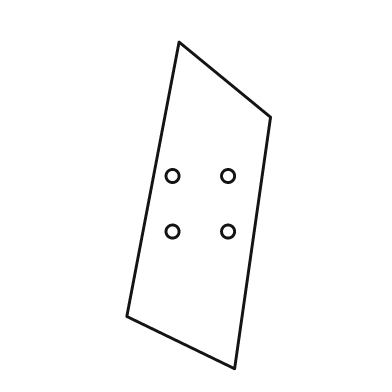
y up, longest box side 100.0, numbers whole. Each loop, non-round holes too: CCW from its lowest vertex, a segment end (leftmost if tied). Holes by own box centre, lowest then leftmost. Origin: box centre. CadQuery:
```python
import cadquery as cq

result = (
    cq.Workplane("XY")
    .moveTo(11.0, -50.0)
    .lineTo(22.0, 27.0)
    .lineTo(-6.0, 50.0)
    .lineTo(-22.0, -34.0)
    .close()
    .moveTo(-8.0, -8.0)
    .circle(2.0)
    .moveTo(9.0, -8.0)
    .circle(2.0)
    .moveTo(-8.0, 9.0)
    .circle(2.0)
    .moveTo(9.0, 9.0)
    .circle(2.0)
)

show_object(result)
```